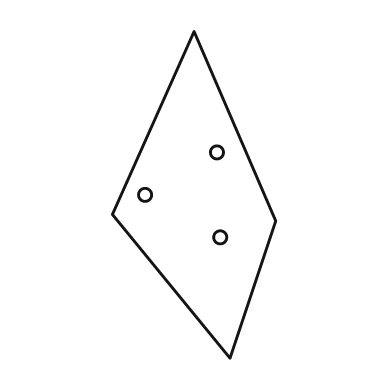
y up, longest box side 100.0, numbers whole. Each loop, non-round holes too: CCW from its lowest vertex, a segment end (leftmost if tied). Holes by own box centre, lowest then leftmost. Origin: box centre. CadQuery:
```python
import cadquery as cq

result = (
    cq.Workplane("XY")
    .moveTo(11.0, -50.0)
    .lineTo(25.0, -8.0)
    .lineTo(0.0, 50.0)
    .lineTo(-25.0, -6.0)
    .close()
    .moveTo(8.0, -13.0)
    .circle(2.0)
    .moveTo(-15.0, 0.0)
    .circle(2.0)
    .moveTo(7.0, 13.0)
    .circle(2.0)
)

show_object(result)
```